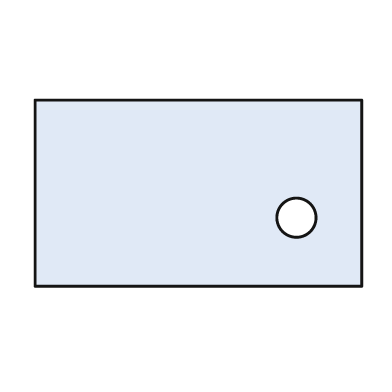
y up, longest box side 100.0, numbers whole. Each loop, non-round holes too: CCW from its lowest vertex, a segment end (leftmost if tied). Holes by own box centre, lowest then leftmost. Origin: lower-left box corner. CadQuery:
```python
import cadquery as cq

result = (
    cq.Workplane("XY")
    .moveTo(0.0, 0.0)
    .lineTo(100.0, 0.0)
    .lineTo(100.0, 57.0)
    .lineTo(0.0, 57.0)
    .close()
    .moveTo(80.0, 21.0)
    .circle(6.0)
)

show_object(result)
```